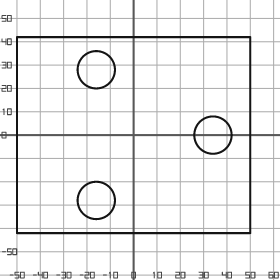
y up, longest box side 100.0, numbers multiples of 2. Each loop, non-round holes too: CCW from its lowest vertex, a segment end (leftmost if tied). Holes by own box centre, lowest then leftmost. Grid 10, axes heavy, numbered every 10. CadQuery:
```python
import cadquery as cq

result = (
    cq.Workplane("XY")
    .moveTo(-50.0, -42.0)
    .lineTo(50.0, -42.0)
    .lineTo(50.0, 42.0)
    .lineTo(-50.0, 42.0)
    .close()
    .moveTo(-16.0, -28.0)
    .circle(8.0)
    .moveTo(34.0, 0.0)
    .circle(8.0)
    .moveTo(-16.0, 28.0)
    .circle(8.0)
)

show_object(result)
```